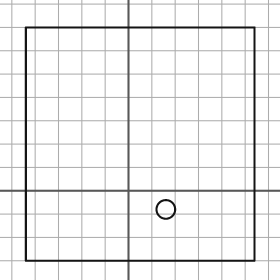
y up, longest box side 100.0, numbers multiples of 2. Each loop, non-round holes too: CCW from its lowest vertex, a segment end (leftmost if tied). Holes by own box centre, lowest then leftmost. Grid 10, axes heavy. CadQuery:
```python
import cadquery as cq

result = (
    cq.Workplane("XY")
    .moveTo(-44.0, -30.0)
    .lineTo(54.0, -30.0)
    .lineTo(54.0, 70.0)
    .lineTo(-44.0, 70.0)
    .close()
    .moveTo(16.0, -8.0)
    .circle(4.0)
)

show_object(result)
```